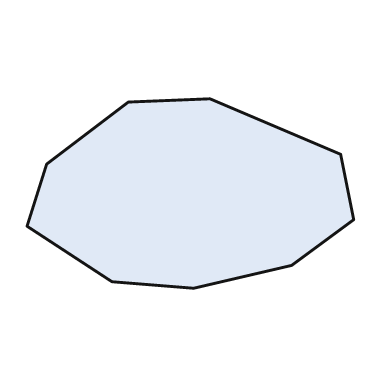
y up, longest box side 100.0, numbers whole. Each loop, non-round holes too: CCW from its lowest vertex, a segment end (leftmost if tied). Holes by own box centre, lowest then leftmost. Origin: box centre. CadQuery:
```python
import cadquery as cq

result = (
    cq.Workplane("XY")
    .moveTo(1.0, -29.0)
    .lineTo(31.0, -22.0)
    .lineTo(50.0, -8.0)
    .lineTo(46.0, 12.0)
    .lineTo(6.0, 29.0)
    .lineTo(-19.0, 28.0)
    .lineTo(-44.0, 9.0)
    .lineTo(-50.0, -10.0)
    .lineTo(-24.0, -27.0)
    .close()
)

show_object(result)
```